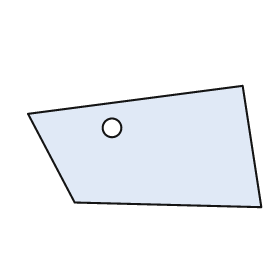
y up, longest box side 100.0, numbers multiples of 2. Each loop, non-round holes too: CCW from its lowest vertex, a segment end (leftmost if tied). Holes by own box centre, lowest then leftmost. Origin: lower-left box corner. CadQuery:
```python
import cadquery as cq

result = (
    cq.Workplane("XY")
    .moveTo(100.0, 0.0)
    .lineTo(92.0, 52.0)
    .lineTo(0.0, 40.0)
    .lineTo(20.0, 2.0)
    .close()
    .moveTo(36.0, 34.0)
    .circle(4.0)
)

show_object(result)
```